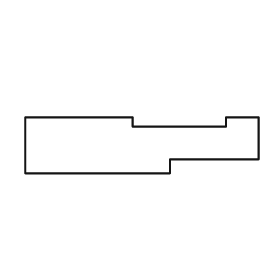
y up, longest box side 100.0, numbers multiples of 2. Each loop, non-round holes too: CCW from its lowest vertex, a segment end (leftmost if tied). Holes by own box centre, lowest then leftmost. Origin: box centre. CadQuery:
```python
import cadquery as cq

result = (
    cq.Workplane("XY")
    .moveTo(-50.0, -12.0)
    .lineTo(12.0, -12.0)
    .lineTo(12.0, -6.0)
    .lineTo(50.0, -6.0)
    .lineTo(50.0, 12.0)
    .lineTo(36.0, 12.0)
    .lineTo(36.0, 8.0)
    .lineTo(-4.0, 8.0)
    .lineTo(-4.0, 12.0)
    .lineTo(-50.0, 12.0)
    .close()
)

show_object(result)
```